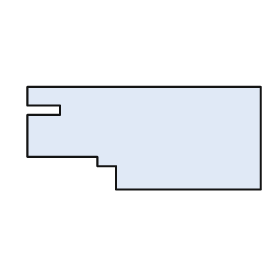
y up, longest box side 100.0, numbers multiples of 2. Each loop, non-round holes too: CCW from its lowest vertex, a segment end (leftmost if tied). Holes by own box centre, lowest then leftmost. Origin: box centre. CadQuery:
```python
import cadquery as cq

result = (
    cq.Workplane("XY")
    .moveTo(-12.0, -22.0)
    .lineTo(50.0, -22.0)
    .lineTo(50.0, 22.0)
    .lineTo(-50.0, 22.0)
    .lineTo(-50.0, 14.0)
    .lineTo(-36.0, 14.0)
    .lineTo(-36.0, 10.0)
    .lineTo(-50.0, 10.0)
    .lineTo(-50.0, -8.0)
    .lineTo(-20.0, -8.0)
    .lineTo(-20.0, -12.0)
    .lineTo(-12.0, -12.0)
    .close()
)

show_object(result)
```